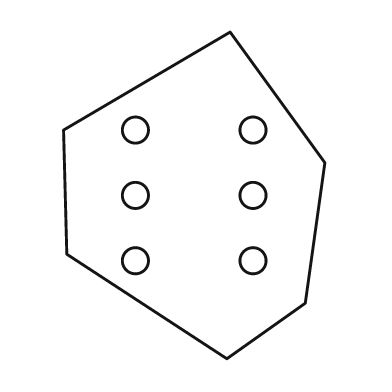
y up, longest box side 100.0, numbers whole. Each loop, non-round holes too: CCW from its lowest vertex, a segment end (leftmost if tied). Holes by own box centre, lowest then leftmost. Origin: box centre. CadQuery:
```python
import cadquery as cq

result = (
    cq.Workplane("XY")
    .moveTo(10.0, -50.0)
    .lineTo(34.0, -33.0)
    .lineTo(40.0, 10.0)
    .lineTo(11.0, 50.0)
    .lineTo(-40.0, 20.0)
    .lineTo(-39.0, -18.0)
    .close()
    .moveTo(-18.0, -20.0)
    .circle(4.0)
    .moveTo(18.0, -20.0)
    .circle(4.0)
    .moveTo(-18.0, 0.0)
    .circle(4.0)
    .moveTo(18.0, 0.0)
    .circle(4.0)
    .moveTo(-18.0, 20.0)
    .circle(4.0)
    .moveTo(18.0, 20.0)
    .circle(4.0)
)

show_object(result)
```